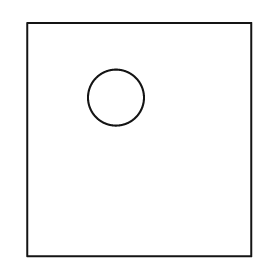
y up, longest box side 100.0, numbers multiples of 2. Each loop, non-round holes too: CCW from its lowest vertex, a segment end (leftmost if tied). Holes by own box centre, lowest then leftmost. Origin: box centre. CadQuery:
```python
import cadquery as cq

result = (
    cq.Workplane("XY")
    .moveTo(-48.0, -50.0)
    .lineTo(48.0, -50.0)
    .lineTo(48.0, 50.0)
    .lineTo(-48.0, 50.0)
    .close()
    .moveTo(-10.0, 18.0)
    .circle(12.0)
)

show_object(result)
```